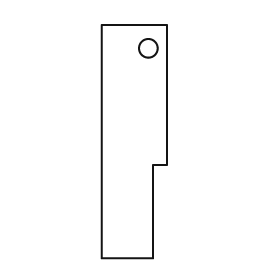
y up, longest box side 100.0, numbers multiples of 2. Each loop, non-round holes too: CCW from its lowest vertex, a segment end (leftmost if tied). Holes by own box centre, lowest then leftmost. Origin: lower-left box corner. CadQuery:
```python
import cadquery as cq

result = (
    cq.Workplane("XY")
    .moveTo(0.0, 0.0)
    .lineTo(22.0, 0.0)
    .lineTo(22.0, 40.0)
    .lineTo(28.0, 40.0)
    .lineTo(28.0, 100.0)
    .lineTo(0.0, 100.0)
    .close()
    .moveTo(20.0, 90.0)
    .circle(4.0)
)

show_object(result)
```